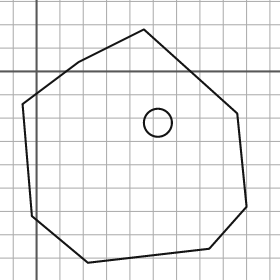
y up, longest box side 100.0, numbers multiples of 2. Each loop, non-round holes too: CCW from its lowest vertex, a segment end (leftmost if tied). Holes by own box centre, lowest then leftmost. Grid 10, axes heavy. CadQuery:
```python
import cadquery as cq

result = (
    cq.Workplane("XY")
    .moveTo(22.0, -82.0)
    .lineTo(74.0, -76.0)
    .lineTo(90.0, -58.0)
    .lineTo(86.0, -18.0)
    .lineTo(46.0, 18.0)
    .lineTo(18.0, 4.0)
    .lineTo(-6.0, -14.0)
    .lineTo(-2.0, -62.0)
    .close()
    .moveTo(52.0, -22.0)
    .circle(6.0)
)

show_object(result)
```